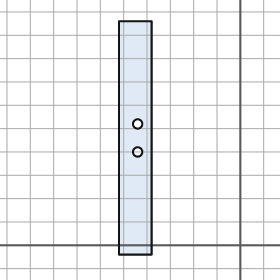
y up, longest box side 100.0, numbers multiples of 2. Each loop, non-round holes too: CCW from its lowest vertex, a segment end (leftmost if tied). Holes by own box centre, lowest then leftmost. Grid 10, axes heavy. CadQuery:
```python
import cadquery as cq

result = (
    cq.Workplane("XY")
    .moveTo(-52.0, -4.0)
    .lineTo(-38.0, -4.0)
    .lineTo(-38.0, 96.0)
    .lineTo(-52.0, 96.0)
    .close()
    .moveTo(-44.0, 40.0)
    .circle(2.0)
    .moveTo(-44.0, 52.0)
    .circle(2.0)
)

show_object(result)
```